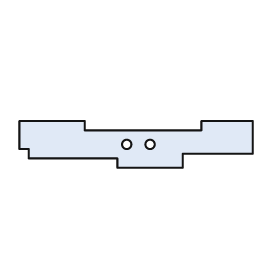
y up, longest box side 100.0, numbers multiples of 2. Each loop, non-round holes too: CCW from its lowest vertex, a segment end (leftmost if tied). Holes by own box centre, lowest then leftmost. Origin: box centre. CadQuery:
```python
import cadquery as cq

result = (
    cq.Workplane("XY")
    .moveTo(-8.0, -10.0)
    .lineTo(20.0, -10.0)
    .lineTo(20.0, -4.0)
    .lineTo(50.0, -4.0)
    .lineTo(50.0, 10.0)
    .lineTo(28.0, 10.0)
    .lineTo(28.0, 6.0)
    .lineTo(-22.0, 6.0)
    .lineTo(-22.0, 10.0)
    .lineTo(-50.0, 10.0)
    .lineTo(-50.0, -2.0)
    .lineTo(-46.0, -2.0)
    .lineTo(-46.0, -6.0)
    .lineTo(-8.0, -6.0)
    .close()
    .moveTo(-4.0, 0.0)
    .circle(2.0)
    .moveTo(6.0, 0.0)
    .circle(2.0)
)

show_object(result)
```